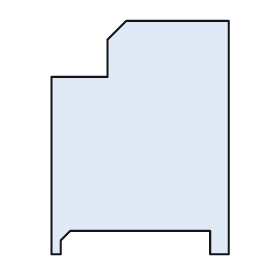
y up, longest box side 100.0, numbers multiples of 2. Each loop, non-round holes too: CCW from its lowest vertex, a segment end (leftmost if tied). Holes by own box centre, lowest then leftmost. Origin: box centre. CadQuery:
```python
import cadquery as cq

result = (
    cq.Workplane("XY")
    .moveTo(-38.0, -50.0)
    .lineTo(-34.0, -50.0)
    .lineTo(-34.0, -44.0)
    .lineTo(-30.0, -40.0)
    .lineTo(30.0, -40.0)
    .lineTo(30.0, -50.0)
    .lineTo(38.0, -50.0)
    .lineTo(38.0, 50.0)
    .lineTo(-6.0, 50.0)
    .lineTo(-14.0, 42.0)
    .lineTo(-14.0, 26.0)
    .lineTo(-38.0, 26.0)
    .close()
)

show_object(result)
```